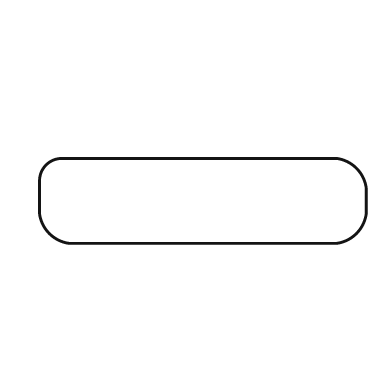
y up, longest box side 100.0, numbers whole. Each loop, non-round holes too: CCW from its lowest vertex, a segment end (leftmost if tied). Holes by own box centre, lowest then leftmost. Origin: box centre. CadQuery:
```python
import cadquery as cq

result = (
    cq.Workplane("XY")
    .moveTo(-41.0, -13.0)
    .lineTo(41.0, -13.0)
    .threePointArc((47.0, -10.0), (50.0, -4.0))
    .lineTo(50.0, 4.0)
    .threePointArc((47.0, 10.0), (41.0, 13.0))
    .lineTo(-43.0, 13.0)
    .threePointArc((-48.0, 11.0), (-50.0, 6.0))
    .lineTo(-50.0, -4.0)
    .threePointArc((-47.0, -10.0), (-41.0, -13.0))
    .close()
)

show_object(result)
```